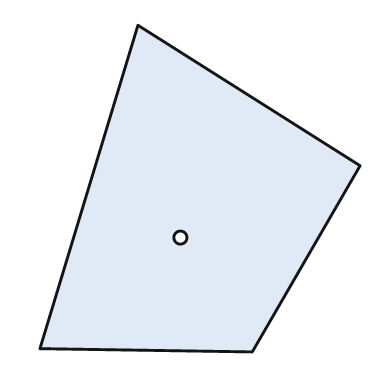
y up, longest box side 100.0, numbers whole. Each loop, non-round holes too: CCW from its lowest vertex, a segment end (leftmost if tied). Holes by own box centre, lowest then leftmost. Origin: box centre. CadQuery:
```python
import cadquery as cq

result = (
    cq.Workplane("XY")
    .moveTo(16.0, -50.0)
    .lineTo(49.0, 7.0)
    .lineTo(-19.0, 50.0)
    .lineTo(-49.0, -49.0)
    .close()
    .moveTo(-6.0, -15.0)
    .circle(2.0)
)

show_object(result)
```